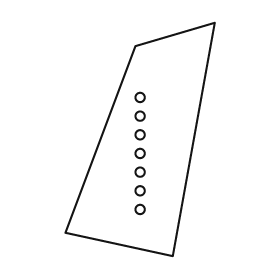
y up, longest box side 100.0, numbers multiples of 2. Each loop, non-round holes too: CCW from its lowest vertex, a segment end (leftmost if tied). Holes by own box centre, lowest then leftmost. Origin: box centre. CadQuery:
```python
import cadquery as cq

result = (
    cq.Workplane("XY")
    .moveTo(14.0, -50.0)
    .lineTo(32.0, 50.0)
    .lineTo(-2.0, 40.0)
    .lineTo(-32.0, -40.0)
    .close()
    .moveTo(0.0, -30.0)
    .circle(2.0)
    .moveTo(0.0, -22.0)
    .circle(2.0)
    .moveTo(0.0, -14.0)
    .circle(2.0)
    .moveTo(0.0, -6.0)
    .circle(2.0)
    .moveTo(0.0, 2.0)
    .circle(2.0)
    .moveTo(0.0, 10.0)
    .circle(2.0)
    .moveTo(0.0, 18.0)
    .circle(2.0)
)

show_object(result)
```